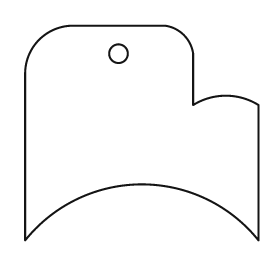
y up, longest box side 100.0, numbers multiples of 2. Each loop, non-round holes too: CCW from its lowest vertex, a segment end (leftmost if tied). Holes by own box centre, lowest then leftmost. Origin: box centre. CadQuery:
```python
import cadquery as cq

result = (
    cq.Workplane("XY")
    .moveTo(-50.0, -46.0)
    .threePointArc((0.0, -22.0), (50.0, -46.0))
    .lineTo(50.0, 12.0)
    .threePointArc((36.0, 16.0), (22.0, 12.0))
    .lineTo(22.0, 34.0)
    .threePointArc((18.0, 42.0), (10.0, 46.0))
    .lineTo(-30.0, 46.0)
    .threePointArc((-44.0, 40.0), (-50.0, 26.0))
    .close()
    .moveTo(-10.0, 34.0)
    .circle(4.0)
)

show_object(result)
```